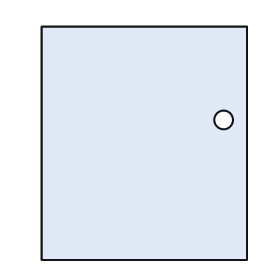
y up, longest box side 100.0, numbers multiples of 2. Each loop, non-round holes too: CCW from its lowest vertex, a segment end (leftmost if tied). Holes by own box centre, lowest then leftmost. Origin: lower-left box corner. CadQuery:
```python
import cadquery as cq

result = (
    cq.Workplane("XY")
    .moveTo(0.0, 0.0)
    .lineTo(88.0, 0.0)
    .lineTo(88.0, 100.0)
    .lineTo(0.0, 100.0)
    .close()
    .moveTo(78.0, 60.0)
    .circle(4.0)
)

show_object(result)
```